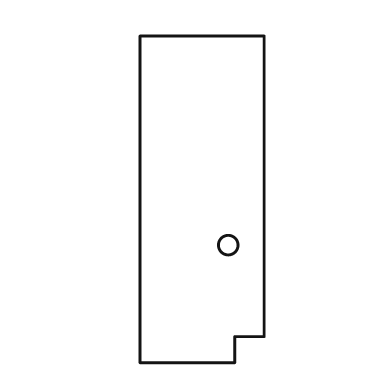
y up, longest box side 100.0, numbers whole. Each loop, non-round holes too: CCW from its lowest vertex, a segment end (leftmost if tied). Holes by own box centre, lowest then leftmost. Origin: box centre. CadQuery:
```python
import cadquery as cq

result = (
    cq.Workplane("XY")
    .moveTo(-19.0, -50.0)
    .lineTo(10.0, -50.0)
    .lineTo(10.0, -42.0)
    .lineTo(19.0, -42.0)
    .lineTo(19.0, 50.0)
    .lineTo(-19.0, 50.0)
    .close()
    .moveTo(8.0, -14.0)
    .circle(3.0)
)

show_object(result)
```